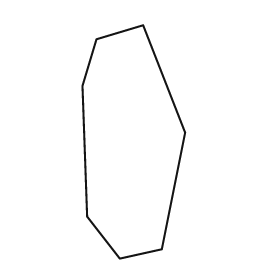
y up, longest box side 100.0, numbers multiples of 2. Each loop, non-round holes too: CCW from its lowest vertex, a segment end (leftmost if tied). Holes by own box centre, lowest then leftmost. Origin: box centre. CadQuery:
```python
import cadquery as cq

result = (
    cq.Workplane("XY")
    .moveTo(-6.0, -50.0)
    .lineTo(12.0, -46.0)
    .lineTo(22.0, 4.0)
    .lineTo(4.0, 50.0)
    .lineTo(-16.0, 44.0)
    .lineTo(-22.0, 24.0)
    .lineTo(-20.0, -32.0)
    .close()
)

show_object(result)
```